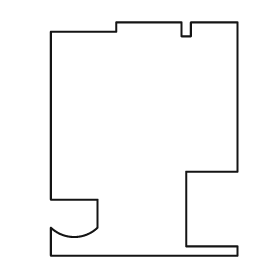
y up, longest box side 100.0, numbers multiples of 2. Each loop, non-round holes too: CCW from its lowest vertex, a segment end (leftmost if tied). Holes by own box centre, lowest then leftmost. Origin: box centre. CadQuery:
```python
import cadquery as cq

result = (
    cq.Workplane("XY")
    .moveTo(-40.0, -50.0)
    .lineTo(40.0, -50.0)
    .lineTo(40.0, -46.0)
    .lineTo(18.0, -46.0)
    .lineTo(18.0, -14.0)
    .lineTo(40.0, -14.0)
    .lineTo(40.0, 50.0)
    .lineTo(20.0, 50.0)
    .lineTo(20.0, 44.0)
    .lineTo(16.0, 44.0)
    .lineTo(16.0, 50.0)
    .lineTo(-12.0, 50.0)
    .lineTo(-12.0, 46.0)
    .lineTo(-40.0, 46.0)
    .lineTo(-40.0, -26.0)
    .lineTo(-20.0, -26.0)
    .lineTo(-20.0, -38.0)
    .threePointArc((-30.0, -42.0), (-40.0, -38.0))
    .close()
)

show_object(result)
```